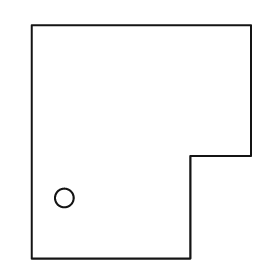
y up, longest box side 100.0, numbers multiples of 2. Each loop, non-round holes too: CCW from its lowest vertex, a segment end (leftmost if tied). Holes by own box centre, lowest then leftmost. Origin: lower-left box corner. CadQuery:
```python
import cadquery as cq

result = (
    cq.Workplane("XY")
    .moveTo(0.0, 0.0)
    .lineTo(68.0, 0.0)
    .lineTo(68.0, 44.0)
    .lineTo(94.0, 44.0)
    .lineTo(94.0, 100.0)
    .lineTo(0.0, 100.0)
    .close()
    .moveTo(14.0, 26.0)
    .circle(4.0)
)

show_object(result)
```